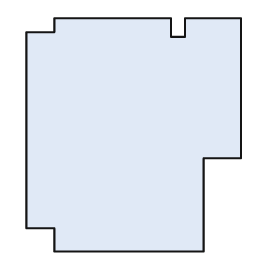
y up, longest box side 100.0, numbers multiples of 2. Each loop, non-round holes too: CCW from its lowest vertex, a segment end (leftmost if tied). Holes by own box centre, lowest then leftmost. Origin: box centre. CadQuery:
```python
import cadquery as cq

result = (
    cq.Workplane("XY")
    .moveTo(-34.0, -50.0)
    .lineTo(30.0, -50.0)
    .lineTo(30.0, -10.0)
    .lineTo(46.0, -10.0)
    .lineTo(46.0, 50.0)
    .lineTo(22.0, 50.0)
    .lineTo(22.0, 42.0)
    .lineTo(16.0, 42.0)
    .lineTo(16.0, 50.0)
    .lineTo(-34.0, 50.0)
    .lineTo(-34.0, 44.0)
    .lineTo(-46.0, 44.0)
    .lineTo(-46.0, -40.0)
    .lineTo(-34.0, -40.0)
    .close()
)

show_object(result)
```